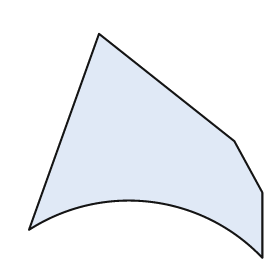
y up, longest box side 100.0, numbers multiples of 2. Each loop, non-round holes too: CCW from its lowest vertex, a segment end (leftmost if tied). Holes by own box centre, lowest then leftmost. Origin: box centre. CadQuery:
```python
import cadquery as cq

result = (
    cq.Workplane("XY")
    .moveTo(50.0, -48.0)
    .lineTo(50.0, -20.0)
    .lineTo(38.0, 2.0)
    .lineTo(-20.0, 48.0)
    .lineTo(-50.0, -36.0)
    .threePointArc((2.0, -24.0), (50.0, -48.0))
    .close()
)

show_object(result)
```